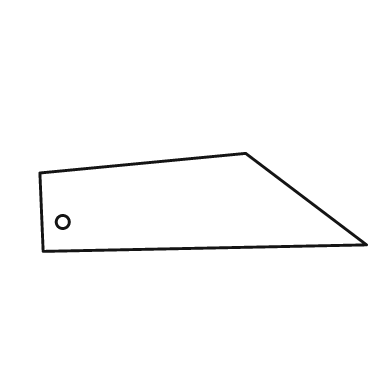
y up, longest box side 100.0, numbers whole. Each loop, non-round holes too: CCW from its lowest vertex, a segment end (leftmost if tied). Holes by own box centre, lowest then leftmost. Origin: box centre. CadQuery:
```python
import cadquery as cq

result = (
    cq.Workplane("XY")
    .moveTo(-49.0, -15.0)
    .lineTo(50.0, -13.0)
    .lineTo(13.0, 15.0)
    .lineTo(-50.0, 9.0)
    .close()
    .moveTo(-43.0, -6.0)
    .circle(2.0)
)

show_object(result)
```